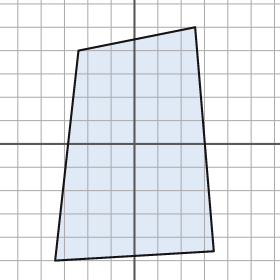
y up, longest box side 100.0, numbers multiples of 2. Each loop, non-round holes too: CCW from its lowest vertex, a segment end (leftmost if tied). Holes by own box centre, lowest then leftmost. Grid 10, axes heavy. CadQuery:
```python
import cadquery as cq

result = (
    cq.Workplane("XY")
    .moveTo(-34.0, -50.0)
    .lineTo(34.0, -46.0)
    .lineTo(26.0, 50.0)
    .lineTo(-24.0, 40.0)
    .close()
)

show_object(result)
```